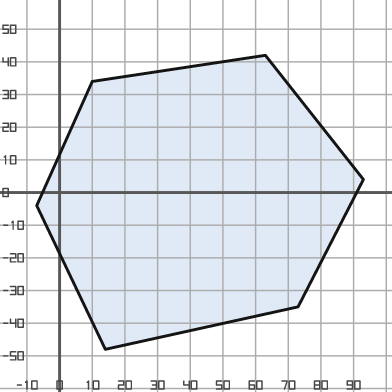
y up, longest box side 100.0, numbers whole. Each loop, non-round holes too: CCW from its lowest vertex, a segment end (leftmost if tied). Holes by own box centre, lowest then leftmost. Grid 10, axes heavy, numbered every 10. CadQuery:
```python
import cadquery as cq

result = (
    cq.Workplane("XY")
    .moveTo(14.0, -48.0)
    .lineTo(73.0, -35.0)
    .lineTo(93.0, 4.0)
    .lineTo(63.0, 42.0)
    .lineTo(10.0, 34.0)
    .lineTo(-7.0, -4.0)
    .close()
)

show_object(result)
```